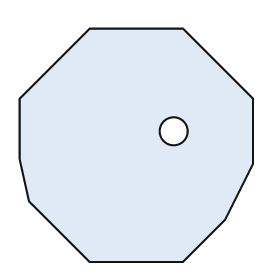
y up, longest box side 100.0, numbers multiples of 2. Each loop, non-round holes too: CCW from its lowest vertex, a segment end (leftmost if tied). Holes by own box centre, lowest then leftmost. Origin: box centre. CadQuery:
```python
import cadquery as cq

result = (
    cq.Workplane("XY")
    .moveTo(-20.0, -50.0)
    .lineTo(20.0, -50.0)
    .lineTo(38.0, -32.0)
    .lineTo(50.0, -8.0)
    .lineTo(50.0, 20.0)
    .lineTo(20.0, 50.0)
    .lineTo(-20.0, 50.0)
    .lineTo(-50.0, 20.0)
    .lineTo(-50.0, -6.0)
    .lineTo(-46.0, -24.0)
    .close()
    .moveTo(16.0, 6.0)
    .circle(6.0)
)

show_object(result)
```